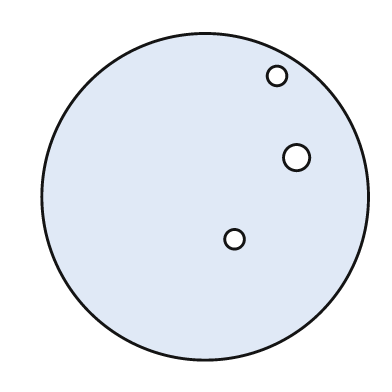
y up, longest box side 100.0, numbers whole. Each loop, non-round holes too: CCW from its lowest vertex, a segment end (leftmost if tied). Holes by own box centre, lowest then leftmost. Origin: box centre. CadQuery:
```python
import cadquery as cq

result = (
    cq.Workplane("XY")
    .moveTo(0.0, 0.0)
    .circle(50.0)
    .moveTo(9.0, -13.0)
    .circle(3.0)
    .moveTo(28.0, 12.0)
    .circle(4.0)
    .moveTo(22.0, 37.0)
    .circle(3.0)
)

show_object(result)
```